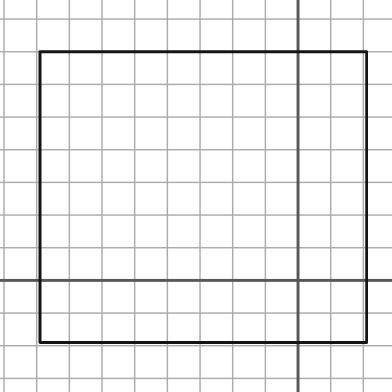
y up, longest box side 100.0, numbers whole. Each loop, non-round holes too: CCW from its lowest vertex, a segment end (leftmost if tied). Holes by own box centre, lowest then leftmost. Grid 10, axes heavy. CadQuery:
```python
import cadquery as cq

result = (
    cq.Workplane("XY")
    .moveTo(-79.0, -19.0)
    .lineTo(21.0, -19.0)
    .lineTo(21.0, 70.0)
    .lineTo(-79.0, 70.0)
    .close()
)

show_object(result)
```